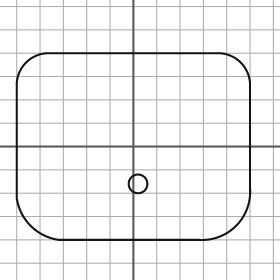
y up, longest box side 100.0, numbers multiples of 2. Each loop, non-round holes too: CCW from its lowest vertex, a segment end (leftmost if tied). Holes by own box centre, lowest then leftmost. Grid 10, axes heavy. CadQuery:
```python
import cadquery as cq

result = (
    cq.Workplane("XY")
    .moveTo(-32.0, -40.0)
    .lineTo(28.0, -40.0)
    .threePointArc((44.0, -34.0), (50.0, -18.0))
    .lineTo(50.0, 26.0)
    .threePointArc((46.0, 36.0), (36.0, 40.0))
    .lineTo(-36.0, 40.0)
    .threePointArc((-46.0, 36.0), (-50.0, 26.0))
    .lineTo(-50.0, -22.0)
    .threePointArc((-44.0, -34.0), (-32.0, -40.0))
    .close()
    .moveTo(2.0, -16.0)
    .circle(4.0)
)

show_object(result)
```